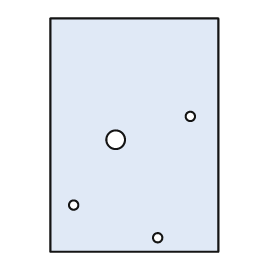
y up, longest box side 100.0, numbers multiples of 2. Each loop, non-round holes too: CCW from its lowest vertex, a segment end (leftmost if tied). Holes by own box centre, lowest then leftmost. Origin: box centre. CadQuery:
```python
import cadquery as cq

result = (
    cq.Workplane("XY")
    .moveTo(-36.0, -50.0)
    .lineTo(36.0, -50.0)
    .lineTo(36.0, 50.0)
    .lineTo(-36.0, 50.0)
    .close()
    .moveTo(10.0, -44.0)
    .circle(2.0)
    .moveTo(-26.0, -30.0)
    .circle(2.0)
    .moveTo(-8.0, -2.0)
    .circle(4.0)
    .moveTo(24.0, 8.0)
    .circle(2.0)
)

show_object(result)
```